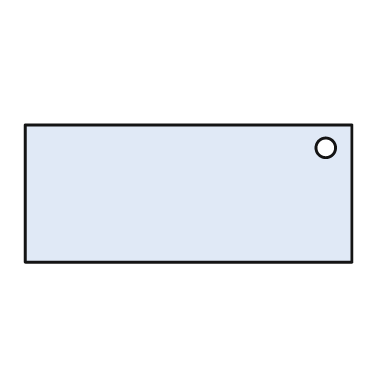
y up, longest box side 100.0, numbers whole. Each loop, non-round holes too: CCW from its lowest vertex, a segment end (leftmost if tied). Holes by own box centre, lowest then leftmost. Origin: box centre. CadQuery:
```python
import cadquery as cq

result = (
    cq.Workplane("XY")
    .moveTo(-50.0, -21.0)
    .lineTo(50.0, -21.0)
    .lineTo(50.0, 21.0)
    .lineTo(-50.0, 21.0)
    .close()
    .moveTo(42.0, 14.0)
    .circle(3.0)
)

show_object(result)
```